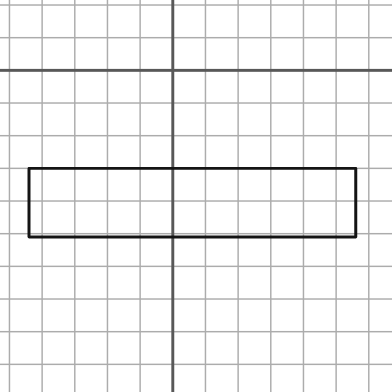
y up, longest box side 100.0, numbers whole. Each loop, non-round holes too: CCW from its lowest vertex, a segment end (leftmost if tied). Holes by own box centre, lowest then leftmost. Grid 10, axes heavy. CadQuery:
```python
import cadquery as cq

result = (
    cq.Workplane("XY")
    .moveTo(-44.0, -51.0)
    .lineTo(56.0, -51.0)
    .lineTo(56.0, -30.0)
    .lineTo(-44.0, -30.0)
    .close()
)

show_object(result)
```